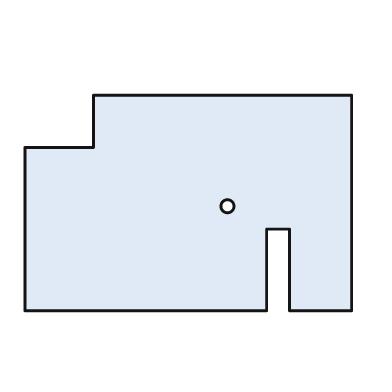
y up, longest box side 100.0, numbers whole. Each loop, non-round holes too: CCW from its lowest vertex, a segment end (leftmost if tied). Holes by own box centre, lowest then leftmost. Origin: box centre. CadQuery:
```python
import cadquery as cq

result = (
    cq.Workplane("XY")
    .moveTo(-50.0, -33.0)
    .lineTo(24.0, -33.0)
    .lineTo(24.0, -8.0)
    .lineTo(31.0, -8.0)
    .lineTo(31.0, -33.0)
    .lineTo(50.0, -33.0)
    .lineTo(50.0, 33.0)
    .lineTo(-29.0, 33.0)
    .lineTo(-29.0, 17.0)
    .lineTo(-50.0, 17.0)
    .close()
    .moveTo(12.0, -1.0)
    .circle(2.0)
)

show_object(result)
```